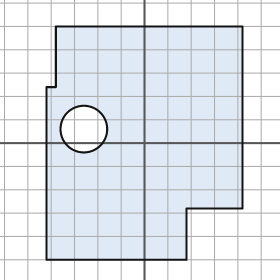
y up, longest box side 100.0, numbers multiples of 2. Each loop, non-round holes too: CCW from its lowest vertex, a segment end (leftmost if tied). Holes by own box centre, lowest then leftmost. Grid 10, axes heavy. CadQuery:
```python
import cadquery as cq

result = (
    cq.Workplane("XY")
    .moveTo(-42.0, -50.0)
    .lineTo(18.0, -50.0)
    .lineTo(18.0, -28.0)
    .lineTo(42.0, -28.0)
    .lineTo(42.0, 50.0)
    .lineTo(-38.0, 50.0)
    .lineTo(-38.0, 24.0)
    .lineTo(-42.0, 24.0)
    .close()
    .moveTo(-26.0, 6.0)
    .circle(10.0)
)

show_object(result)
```